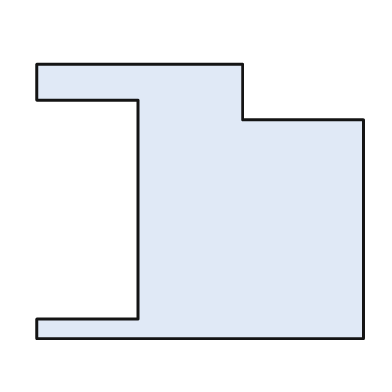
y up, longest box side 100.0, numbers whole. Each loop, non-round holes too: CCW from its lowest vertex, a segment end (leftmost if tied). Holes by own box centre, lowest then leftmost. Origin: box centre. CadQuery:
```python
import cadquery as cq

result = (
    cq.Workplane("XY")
    .moveTo(-50.0, -42.0)
    .lineTo(50.0, -42.0)
    .lineTo(50.0, 25.0)
    .lineTo(13.0, 25.0)
    .lineTo(13.0, 42.0)
    .lineTo(-50.0, 42.0)
    .lineTo(-50.0, 31.0)
    .lineTo(-19.0, 31.0)
    .lineTo(-19.0, -36.0)
    .lineTo(-50.0, -36.0)
    .close()
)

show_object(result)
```